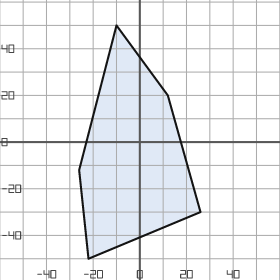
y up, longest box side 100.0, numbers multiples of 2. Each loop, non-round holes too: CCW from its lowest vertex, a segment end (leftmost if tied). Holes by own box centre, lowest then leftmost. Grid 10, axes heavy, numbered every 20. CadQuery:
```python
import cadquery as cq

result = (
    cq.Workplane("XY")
    .moveTo(-22.0, -50.0)
    .lineTo(26.0, -30.0)
    .lineTo(12.0, 20.0)
    .lineTo(-10.0, 50.0)
    .lineTo(-26.0, -12.0)
    .close()
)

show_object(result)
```